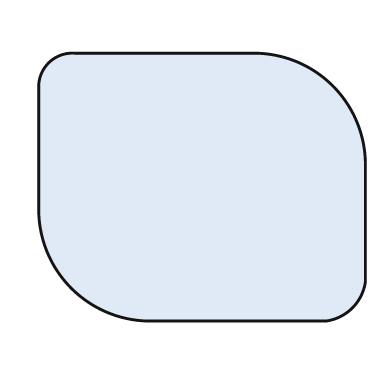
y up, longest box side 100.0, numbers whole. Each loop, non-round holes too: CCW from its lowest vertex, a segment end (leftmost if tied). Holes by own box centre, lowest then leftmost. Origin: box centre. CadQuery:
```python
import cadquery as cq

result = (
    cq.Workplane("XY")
    .moveTo(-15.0, -41.0)
    .lineTo(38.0, -41.0)
    .threePointArc((46.0, -37.0), (50.0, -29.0))
    .lineTo(50.0, 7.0)
    .threePointArc((40.0, 31.0), (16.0, 41.0))
    .lineTo(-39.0, 41.0)
    .threePointArc((-47.0, 38.0), (-50.0, 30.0))
    .lineTo(-50.0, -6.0)
    .threePointArc((-40.0, -31.0), (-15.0, -41.0))
    .close()
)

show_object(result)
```